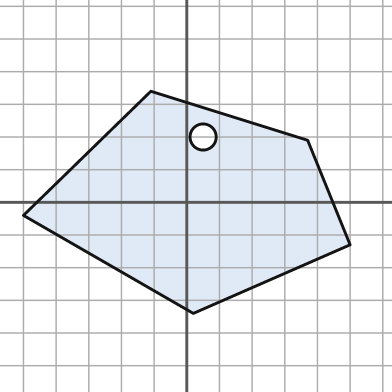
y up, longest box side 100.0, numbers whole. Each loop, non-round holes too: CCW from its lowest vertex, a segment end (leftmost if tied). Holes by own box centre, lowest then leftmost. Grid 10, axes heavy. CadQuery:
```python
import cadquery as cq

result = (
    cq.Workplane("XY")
    .moveTo(2.0, -34.0)
    .lineTo(50.0, -13.0)
    .lineTo(37.0, 19.0)
    .lineTo(-11.0, 34.0)
    .lineTo(-50.0, -4.0)
    .close()
    .moveTo(5.0, 20.0)
    .circle(4.0)
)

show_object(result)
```